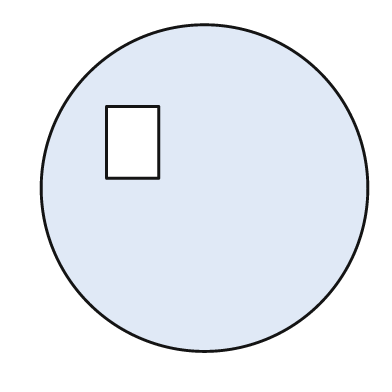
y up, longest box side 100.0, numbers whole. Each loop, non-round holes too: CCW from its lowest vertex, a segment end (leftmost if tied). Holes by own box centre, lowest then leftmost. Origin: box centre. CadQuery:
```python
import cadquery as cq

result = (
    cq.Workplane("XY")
    .moveTo(0.0, 0.0)
    .circle(50.0)
    .moveTo(-30.0, 3.0)
    .lineTo(-14.0, 3.0)
    .lineTo(-14.0, 25.0)
    .lineTo(-30.0, 25.0)
    .close()
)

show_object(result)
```